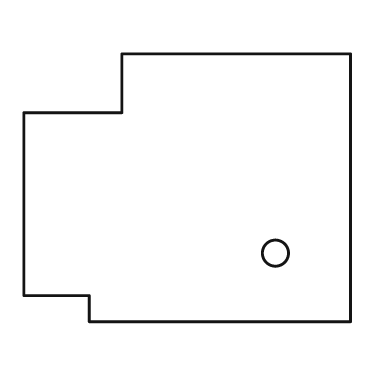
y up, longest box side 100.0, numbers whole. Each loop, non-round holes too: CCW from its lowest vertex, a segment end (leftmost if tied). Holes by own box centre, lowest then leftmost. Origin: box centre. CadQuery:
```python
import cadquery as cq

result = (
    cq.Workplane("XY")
    .moveTo(-30.0, -41.0)
    .lineTo(50.0, -41.0)
    .lineTo(50.0, 41.0)
    .lineTo(-20.0, 41.0)
    .lineTo(-20.0, 23.0)
    .lineTo(-50.0, 23.0)
    .lineTo(-50.0, -33.0)
    .lineTo(-30.0, -33.0)
    .close()
    .moveTo(27.0, -20.0)
    .circle(4.0)
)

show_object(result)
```